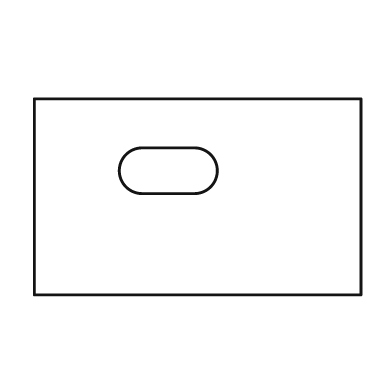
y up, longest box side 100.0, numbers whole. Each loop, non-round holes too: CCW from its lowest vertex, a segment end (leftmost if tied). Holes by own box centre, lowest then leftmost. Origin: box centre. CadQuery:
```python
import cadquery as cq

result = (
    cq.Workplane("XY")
    .moveTo(-50.0, -30.0)
    .lineTo(50.0, -30.0)
    .lineTo(50.0, 30.0)
    .lineTo(-50.0, 30.0)
    .close()
    .moveTo(-17.0, 1.0)
    .lineTo(-1.0, 1.0)
    .threePointArc((6.0, 8.0), (-1.0, 15.0))
    .lineTo(-17.0, 15.0)
    .threePointArc((-24.0, 8.0), (-17.0, 1.0))
    .close()
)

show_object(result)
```